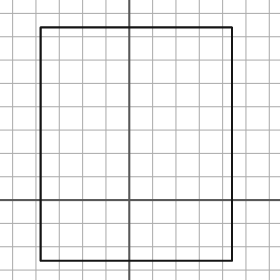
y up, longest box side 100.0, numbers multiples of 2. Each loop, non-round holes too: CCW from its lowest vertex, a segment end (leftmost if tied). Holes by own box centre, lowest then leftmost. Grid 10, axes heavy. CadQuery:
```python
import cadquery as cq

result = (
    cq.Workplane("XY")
    .moveTo(-38.0, -26.0)
    .lineTo(44.0, -26.0)
    .lineTo(44.0, 74.0)
    .lineTo(-38.0, 74.0)
    .close()
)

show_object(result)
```